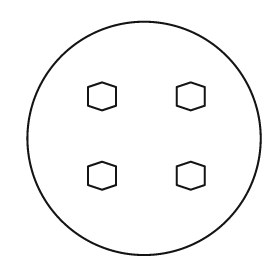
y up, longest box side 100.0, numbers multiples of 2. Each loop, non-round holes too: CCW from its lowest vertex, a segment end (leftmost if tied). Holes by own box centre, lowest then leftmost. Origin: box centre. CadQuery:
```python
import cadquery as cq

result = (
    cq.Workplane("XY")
    .moveTo(0.0, 0.0)
    .circle(50.0)
    .moveTo(-18.0, -22.0)
    .lineTo(-12.0, -20.0)
    .lineTo(-12.0, -12.0)
    .lineTo(-18.0, -10.0)
    .lineTo(-24.0, -12.0)
    .lineTo(-24.0, -20.0)
    .close()
    .moveTo(20.0, -22.0)
    .lineTo(26.0, -20.0)
    .lineTo(26.0, -12.0)
    .lineTo(20.0, -10.0)
    .lineTo(14.0, -12.0)
    .lineTo(14.0, -20.0)
    .close()
    .moveTo(-18.0, 12.0)
    .lineTo(-12.0, 14.0)
    .lineTo(-12.0, 22.0)
    .lineTo(-18.0, 24.0)
    .lineTo(-24.0, 22.0)
    .lineTo(-24.0, 14.0)
    .close()
    .moveTo(20.0, 12.0)
    .lineTo(26.0, 14.0)
    .lineTo(26.0, 22.0)
    .lineTo(20.0, 24.0)
    .lineTo(14.0, 22.0)
    .lineTo(14.0, 14.0)
    .close()
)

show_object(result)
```